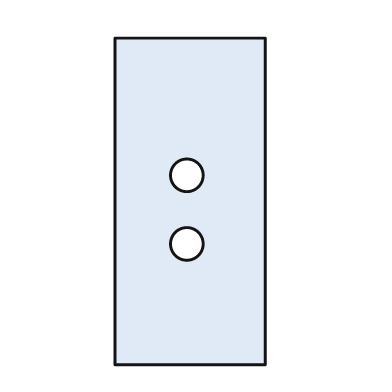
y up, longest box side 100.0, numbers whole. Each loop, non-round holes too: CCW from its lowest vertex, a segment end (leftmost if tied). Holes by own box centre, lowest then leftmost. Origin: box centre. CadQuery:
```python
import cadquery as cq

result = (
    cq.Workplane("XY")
    .moveTo(-23.0, -50.0)
    .lineTo(23.0, -50.0)
    .lineTo(23.0, 50.0)
    .lineTo(-23.0, 50.0)
    .close()
    .moveTo(-1.0, -13.0)
    .circle(5.0)
    .moveTo(-1.0, 8.0)
    .circle(5.0)
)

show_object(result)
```